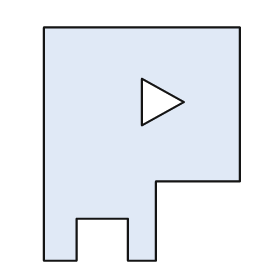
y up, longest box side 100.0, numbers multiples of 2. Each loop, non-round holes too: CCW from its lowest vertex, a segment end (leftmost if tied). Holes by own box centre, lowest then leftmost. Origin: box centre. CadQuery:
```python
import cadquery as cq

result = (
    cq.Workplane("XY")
    .moveTo(-42.0, -50.0)
    .lineTo(-28.0, -50.0)
    .lineTo(-28.0, -32.0)
    .lineTo(-6.0, -32.0)
    .lineTo(-6.0, -50.0)
    .lineTo(6.0, -50.0)
    .lineTo(6.0, -16.0)
    .lineTo(42.0, -16.0)
    .lineTo(42.0, 50.0)
    .lineTo(-42.0, 50.0)
    .close()
    .moveTo(0.0, 8.0)
    .lineTo(18.0, 18.0)
    .lineTo(0.0, 28.0)
    .close()
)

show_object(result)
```